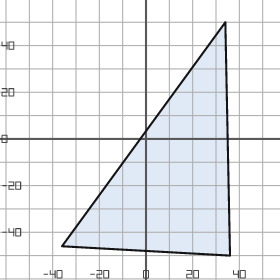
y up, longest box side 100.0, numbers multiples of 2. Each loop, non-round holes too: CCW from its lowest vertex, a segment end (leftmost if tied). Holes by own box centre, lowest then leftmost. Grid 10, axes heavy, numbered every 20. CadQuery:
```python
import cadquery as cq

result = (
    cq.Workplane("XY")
    .moveTo(36.0, -50.0)
    .lineTo(34.0, 50.0)
    .lineTo(-36.0, -46.0)
    .close()
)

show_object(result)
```